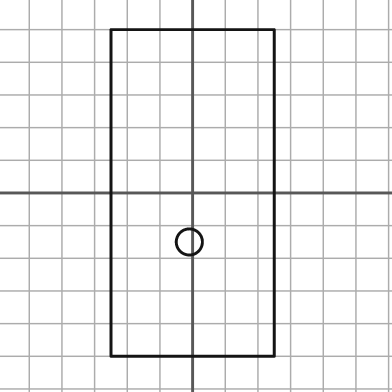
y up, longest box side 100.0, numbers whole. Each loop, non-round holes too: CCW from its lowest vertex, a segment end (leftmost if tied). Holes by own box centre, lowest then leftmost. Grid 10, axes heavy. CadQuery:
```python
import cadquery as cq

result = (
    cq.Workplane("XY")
    .moveTo(-25.0, -50.0)
    .lineTo(25.0, -50.0)
    .lineTo(25.0, 50.0)
    .lineTo(-25.0, 50.0)
    .close()
    .moveTo(-1.0, -15.0)
    .circle(4.0)
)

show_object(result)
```